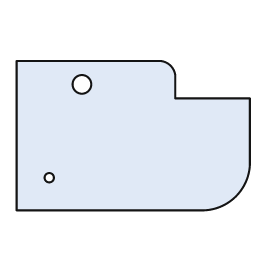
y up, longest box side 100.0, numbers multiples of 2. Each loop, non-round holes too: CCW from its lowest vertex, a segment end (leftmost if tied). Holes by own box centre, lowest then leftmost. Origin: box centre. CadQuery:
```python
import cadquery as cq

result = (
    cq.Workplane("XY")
    .moveTo(-50.0, -32.0)
    .lineTo(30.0, -32.0)
    .threePointArc((44.0, -26.0), (50.0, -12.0))
    .lineTo(50.0, 16.0)
    .lineTo(18.0, 16.0)
    .lineTo(18.0, 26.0)
    .threePointArc((16.0, 30.0), (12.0, 32.0))
    .lineTo(-50.0, 32.0)
    .close()
    .moveTo(-36.0, -18.0)
    .circle(2.0)
    .moveTo(-22.0, 22.0)
    .circle(4.0)
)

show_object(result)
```